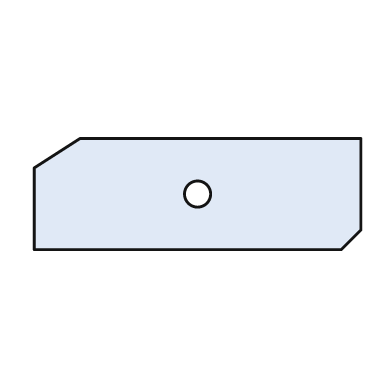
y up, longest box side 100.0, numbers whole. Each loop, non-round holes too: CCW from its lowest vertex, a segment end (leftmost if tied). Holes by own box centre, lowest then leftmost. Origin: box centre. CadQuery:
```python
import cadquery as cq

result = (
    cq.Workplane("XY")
    .moveTo(-50.0, -17.0)
    .lineTo(44.0, -17.0)
    .lineTo(50.0, -11.0)
    .lineTo(50.0, 17.0)
    .lineTo(-36.0, 17.0)
    .lineTo(-50.0, 8.0)
    .close()
    .moveTo(0.0, 0.0)
    .circle(4.0)
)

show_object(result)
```